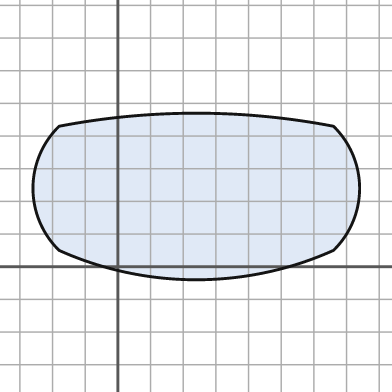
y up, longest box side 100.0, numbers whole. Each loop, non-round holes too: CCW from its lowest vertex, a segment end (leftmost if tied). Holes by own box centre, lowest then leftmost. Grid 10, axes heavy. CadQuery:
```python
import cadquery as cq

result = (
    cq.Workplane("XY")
    .moveTo(-18.0, 5.0)
    .threePointArc((24.0, -4.0), (66.0, 5.0))
    .threePointArc((74.0, 24.0), (66.0, 43.0))
    .threePointArc((24.0, 47.0), (-18.0, 43.0))
    .threePointArc((-26.0, 24.0), (-18.0, 5.0))
    .close()
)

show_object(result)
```